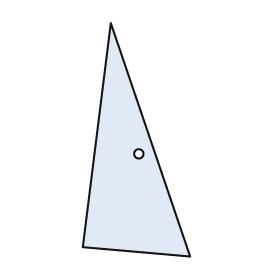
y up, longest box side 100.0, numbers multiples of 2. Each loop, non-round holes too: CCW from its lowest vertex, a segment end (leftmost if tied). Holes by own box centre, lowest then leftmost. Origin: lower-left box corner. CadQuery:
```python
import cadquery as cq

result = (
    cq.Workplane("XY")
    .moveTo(46.0, 0.0)
    .lineTo(12.0, 100.0)
    .lineTo(0.0, 4.0)
    .close()
    .moveTo(24.0, 44.0)
    .circle(2.0)
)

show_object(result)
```